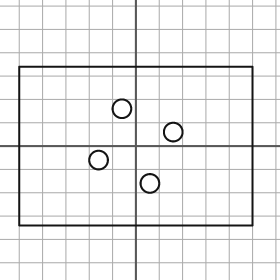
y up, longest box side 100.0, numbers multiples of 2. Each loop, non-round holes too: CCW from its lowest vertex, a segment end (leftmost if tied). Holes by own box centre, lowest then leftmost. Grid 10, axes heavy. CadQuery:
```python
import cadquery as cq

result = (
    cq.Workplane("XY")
    .moveTo(-50.0, -34.0)
    .lineTo(50.0, -34.0)
    .lineTo(50.0, 34.0)
    .lineTo(-50.0, 34.0)
    .close()
    .moveTo(6.0, -16.0)
    .circle(4.0)
    .moveTo(-16.0, -6.0)
    .circle(4.0)
    .moveTo(16.0, 6.0)
    .circle(4.0)
    .moveTo(-6.0, 16.0)
    .circle(4.0)
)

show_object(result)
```